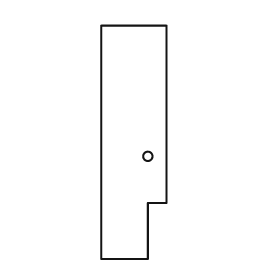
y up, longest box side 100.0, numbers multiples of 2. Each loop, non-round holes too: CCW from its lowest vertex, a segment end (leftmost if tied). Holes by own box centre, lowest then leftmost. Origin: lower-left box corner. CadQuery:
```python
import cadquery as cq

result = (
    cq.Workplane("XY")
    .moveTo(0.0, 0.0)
    .lineTo(20.0, 0.0)
    .lineTo(20.0, 24.0)
    .lineTo(28.0, 24.0)
    .lineTo(28.0, 100.0)
    .lineTo(0.0, 100.0)
    .close()
    .moveTo(20.0, 44.0)
    .circle(2.0)
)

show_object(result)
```